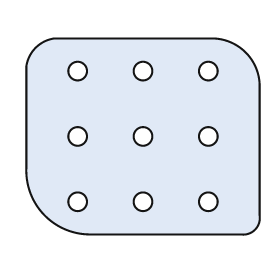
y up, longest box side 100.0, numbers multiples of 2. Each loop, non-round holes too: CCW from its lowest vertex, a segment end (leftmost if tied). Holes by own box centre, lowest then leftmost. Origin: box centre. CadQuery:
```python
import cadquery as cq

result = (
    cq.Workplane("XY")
    .moveTo(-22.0, -42.0)
    .lineTo(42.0, -42.0)
    .threePointArc((48.0, -40.0), (50.0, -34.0))
    .lineTo(50.0, 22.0)
    .threePointArc((44.0, 36.0), (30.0, 42.0))
    .lineTo(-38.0, 42.0)
    .threePointArc((-46.0, 38.0), (-50.0, 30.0))
    .lineTo(-50.0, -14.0)
    .threePointArc((-42.0, -34.0), (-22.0, -42.0))
    .close()
    .moveTo(-28.0, -28.0)
    .circle(4.0)
    .moveTo(0.0, -28.0)
    .circle(4.0)
    .moveTo(28.0, -28.0)
    .circle(4.0)
    .moveTo(-28.0, 0.0)
    .circle(4.0)
    .moveTo(0.0, 0.0)
    .circle(4.0)
    .moveTo(28.0, 0.0)
    .circle(4.0)
    .moveTo(-28.0, 28.0)
    .circle(4.0)
    .moveTo(0.0, 28.0)
    .circle(4.0)
    .moveTo(28.0, 28.0)
    .circle(4.0)
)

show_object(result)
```